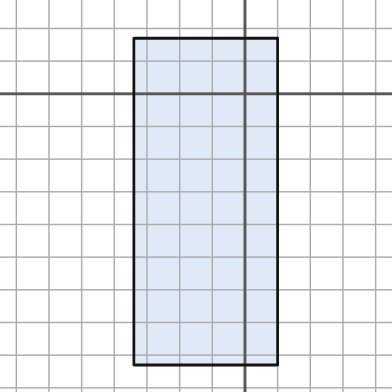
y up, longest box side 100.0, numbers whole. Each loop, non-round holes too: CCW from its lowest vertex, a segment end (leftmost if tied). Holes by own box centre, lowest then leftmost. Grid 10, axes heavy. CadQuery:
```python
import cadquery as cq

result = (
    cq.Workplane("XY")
    .moveTo(-34.0, -83.0)
    .lineTo(10.0, -83.0)
    .lineTo(10.0, 17.0)
    .lineTo(-34.0, 17.0)
    .close()
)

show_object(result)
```